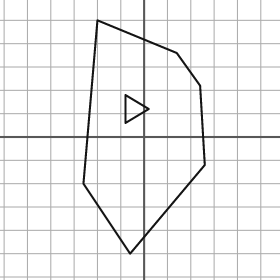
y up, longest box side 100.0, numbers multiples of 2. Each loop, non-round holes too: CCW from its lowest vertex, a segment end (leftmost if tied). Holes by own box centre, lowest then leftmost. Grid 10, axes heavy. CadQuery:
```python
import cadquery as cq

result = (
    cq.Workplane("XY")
    .moveTo(-6.0, -50.0)
    .lineTo(26.0, -12.0)
    .lineTo(24.0, 22.0)
    .lineTo(14.0, 36.0)
    .lineTo(-20.0, 50.0)
    .lineTo(-26.0, -20.0)
    .close()
    .moveTo(-8.0, 6.0)
    .lineTo(2.0, 12.0)
    .lineTo(-8.0, 18.0)
    .close()
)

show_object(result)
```